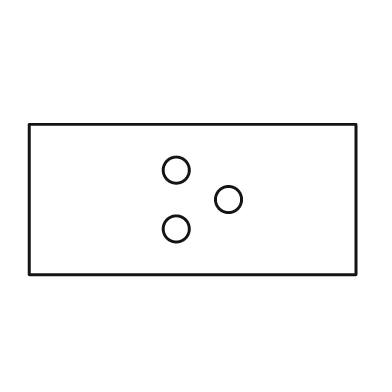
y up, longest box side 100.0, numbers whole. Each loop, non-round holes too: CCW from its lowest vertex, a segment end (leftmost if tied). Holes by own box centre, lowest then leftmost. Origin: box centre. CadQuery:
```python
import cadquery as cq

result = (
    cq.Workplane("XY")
    .moveTo(-50.0, -23.0)
    .lineTo(50.0, -23.0)
    .lineTo(50.0, 23.0)
    .lineTo(-50.0, 23.0)
    .close()
    .moveTo(-5.0, -9.0)
    .circle(4.0)
    .moveTo(11.0, 0.0)
    .circle(4.0)
    .moveTo(-5.0, 9.0)
    .circle(4.0)
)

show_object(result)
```